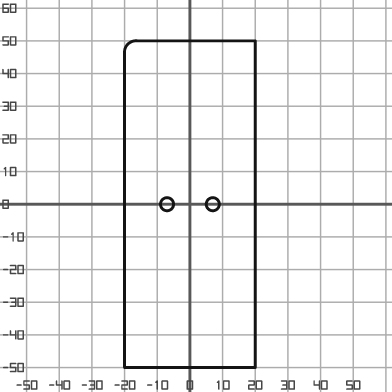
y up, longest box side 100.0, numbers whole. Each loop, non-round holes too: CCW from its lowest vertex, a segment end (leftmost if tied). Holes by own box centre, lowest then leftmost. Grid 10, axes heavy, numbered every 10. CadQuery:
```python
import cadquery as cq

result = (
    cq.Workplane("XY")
    .moveTo(-20.0, -50.0)
    .lineTo(20.0, -50.0)
    .lineTo(20.0, 50.0)
    .lineTo(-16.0, 50.0)
    .threePointArc((-19.0, 49.0), (-20.0, 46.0))
    .close()
    .moveTo(-7.0, 0.0)
    .circle(2.0)
    .moveTo(7.0, 0.0)
    .circle(2.0)
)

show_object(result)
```